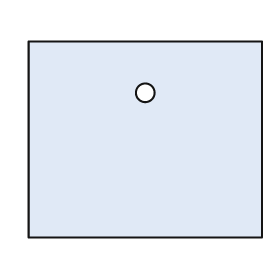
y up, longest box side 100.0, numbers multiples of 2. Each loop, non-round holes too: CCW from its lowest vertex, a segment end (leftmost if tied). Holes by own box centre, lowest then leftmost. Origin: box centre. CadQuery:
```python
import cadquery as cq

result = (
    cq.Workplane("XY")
    .moveTo(-50.0, -42.0)
    .lineTo(50.0, -42.0)
    .lineTo(50.0, 42.0)
    .lineTo(-50.0, 42.0)
    .close()
    .moveTo(0.0, 20.0)
    .circle(4.0)
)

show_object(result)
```